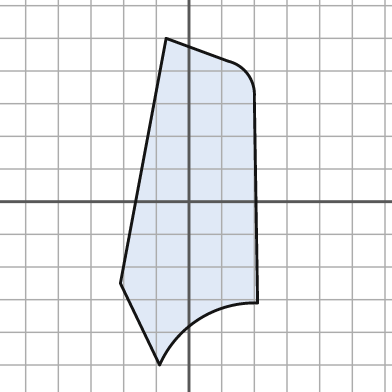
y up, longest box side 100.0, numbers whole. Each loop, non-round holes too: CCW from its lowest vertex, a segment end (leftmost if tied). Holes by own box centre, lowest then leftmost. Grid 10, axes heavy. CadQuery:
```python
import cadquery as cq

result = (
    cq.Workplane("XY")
    .moveTo(-9.0, -50.0)
    .threePointArc((3.0, -36.0), (21.0, -31.0))
    .lineTo(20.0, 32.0)
    .threePointArc((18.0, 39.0), (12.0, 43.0))
    .lineTo(-7.0, 50.0)
    .lineTo(-21.0, -25.0)
    .close()
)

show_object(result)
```